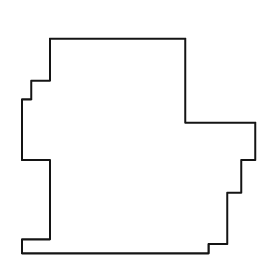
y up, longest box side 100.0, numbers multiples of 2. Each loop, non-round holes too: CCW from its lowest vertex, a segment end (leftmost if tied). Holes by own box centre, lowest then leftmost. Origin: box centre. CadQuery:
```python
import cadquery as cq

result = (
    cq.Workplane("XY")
    .moveTo(-50.0, -46.0)
    .lineTo(30.0, -46.0)
    .lineTo(30.0, -42.0)
    .lineTo(38.0, -42.0)
    .lineTo(38.0, -20.0)
    .lineTo(44.0, -20.0)
    .lineTo(44.0, -6.0)
    .lineTo(50.0, -6.0)
    .lineTo(50.0, 10.0)
    .lineTo(20.0, 10.0)
    .lineTo(20.0, 46.0)
    .lineTo(-38.0, 46.0)
    .lineTo(-38.0, 28.0)
    .lineTo(-46.0, 28.0)
    .lineTo(-46.0, 20.0)
    .lineTo(-50.0, 20.0)
    .lineTo(-50.0, -6.0)
    .lineTo(-38.0, -6.0)
    .lineTo(-38.0, -40.0)
    .lineTo(-50.0, -40.0)
    .close()
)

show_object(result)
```